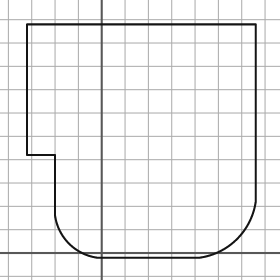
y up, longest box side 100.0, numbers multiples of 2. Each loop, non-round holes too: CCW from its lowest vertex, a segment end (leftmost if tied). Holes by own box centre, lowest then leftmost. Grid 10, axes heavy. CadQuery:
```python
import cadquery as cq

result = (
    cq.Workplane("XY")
    .moveTo(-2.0, -2.0)
    .lineTo(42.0, -2.0)
    .threePointArc((58.0, 6.0), (66.0, 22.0))
    .lineTo(66.0, 98.0)
    .lineTo(-32.0, 98.0)
    .lineTo(-32.0, 42.0)
    .lineTo(-20.0, 42.0)
    .lineTo(-20.0, 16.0)
    .threePointArc((-14.0, 4.0), (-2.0, -2.0))
    .close()
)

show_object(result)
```